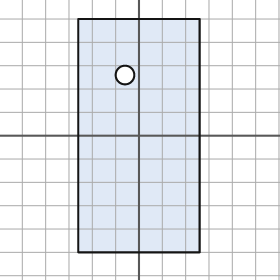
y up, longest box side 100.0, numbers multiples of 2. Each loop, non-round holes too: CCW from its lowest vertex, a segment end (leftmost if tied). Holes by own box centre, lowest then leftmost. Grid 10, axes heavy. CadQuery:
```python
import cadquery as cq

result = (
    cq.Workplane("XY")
    .moveTo(-26.0, -50.0)
    .lineTo(26.0, -50.0)
    .lineTo(26.0, 50.0)
    .lineTo(-26.0, 50.0)
    .close()
    .moveTo(-6.0, 26.0)
    .circle(4.0)
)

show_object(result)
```